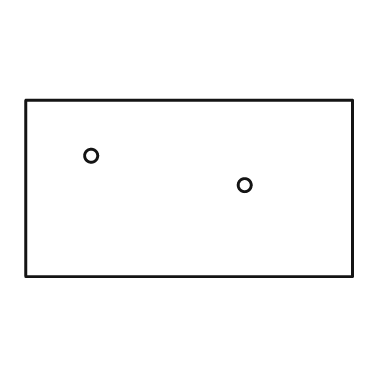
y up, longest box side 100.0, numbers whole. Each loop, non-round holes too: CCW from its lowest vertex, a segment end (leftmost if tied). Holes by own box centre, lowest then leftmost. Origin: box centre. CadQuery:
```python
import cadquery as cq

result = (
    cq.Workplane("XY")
    .moveTo(-50.0, -27.0)
    .lineTo(50.0, -27.0)
    .lineTo(50.0, 27.0)
    .lineTo(-50.0, 27.0)
    .close()
    .moveTo(17.0, 1.0)
    .circle(2.0)
    .moveTo(-30.0, 10.0)
    .circle(2.0)
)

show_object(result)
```